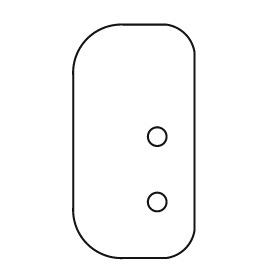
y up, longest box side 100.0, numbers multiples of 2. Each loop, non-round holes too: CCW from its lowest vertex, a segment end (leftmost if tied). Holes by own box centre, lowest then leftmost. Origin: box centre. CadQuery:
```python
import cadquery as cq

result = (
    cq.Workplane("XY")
    .moveTo(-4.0, -50.0)
    .lineTo(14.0, -50.0)
    .threePointArc((22.0, -46.0), (26.0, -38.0))
    .lineTo(26.0, 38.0)
    .threePointArc((22.0, 46.0), (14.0, 50.0))
    .lineTo(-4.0, 50.0)
    .threePointArc((-20.0, 44.0), (-26.0, 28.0))
    .lineTo(-26.0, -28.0)
    .threePointArc((-20.0, -44.0), (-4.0, -50.0))
    .close()
    .moveTo(10.0, -26.0)
    .circle(4.0)
    .moveTo(10.0, 2.0)
    .circle(4.0)
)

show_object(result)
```